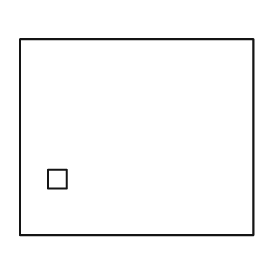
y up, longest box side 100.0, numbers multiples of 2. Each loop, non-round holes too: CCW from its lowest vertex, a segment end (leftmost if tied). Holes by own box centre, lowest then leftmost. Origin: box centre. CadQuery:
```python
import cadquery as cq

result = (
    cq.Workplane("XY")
    .moveTo(-50.0, -42.0)
    .lineTo(50.0, -42.0)
    .lineTo(50.0, 42.0)
    .lineTo(-50.0, 42.0)
    .close()
    .moveTo(-38.0, -22.0)
    .lineTo(-30.0, -22.0)
    .lineTo(-30.0, -14.0)
    .lineTo(-38.0, -14.0)
    .close()
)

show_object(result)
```